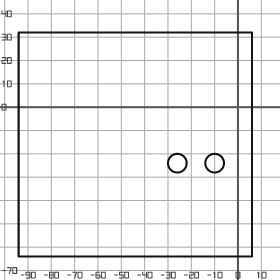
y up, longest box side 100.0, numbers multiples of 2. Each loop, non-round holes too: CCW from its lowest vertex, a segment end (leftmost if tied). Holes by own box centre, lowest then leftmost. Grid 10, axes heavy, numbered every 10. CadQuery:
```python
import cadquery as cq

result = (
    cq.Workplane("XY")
    .moveTo(-94.0, -64.0)
    .lineTo(6.0, -64.0)
    .lineTo(6.0, 32.0)
    .lineTo(-94.0, 32.0)
    .close()
    .moveTo(-26.0, -24.0)
    .circle(4.0)
    .moveTo(-10.0, -24.0)
    .circle(4.0)
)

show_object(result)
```